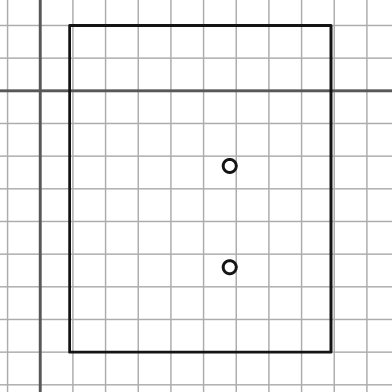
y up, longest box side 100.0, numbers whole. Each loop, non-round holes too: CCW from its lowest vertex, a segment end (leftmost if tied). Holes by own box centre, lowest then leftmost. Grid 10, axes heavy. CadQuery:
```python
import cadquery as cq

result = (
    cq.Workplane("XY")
    .moveTo(9.0, -80.0)
    .lineTo(89.0, -80.0)
    .lineTo(89.0, 20.0)
    .lineTo(9.0, 20.0)
    .close()
    .moveTo(58.0, -54.0)
    .circle(2.0)
    .moveTo(58.0, -23.0)
    .circle(2.0)
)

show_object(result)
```